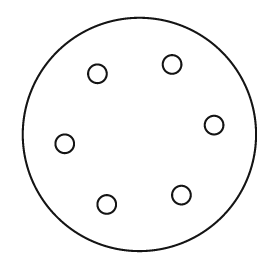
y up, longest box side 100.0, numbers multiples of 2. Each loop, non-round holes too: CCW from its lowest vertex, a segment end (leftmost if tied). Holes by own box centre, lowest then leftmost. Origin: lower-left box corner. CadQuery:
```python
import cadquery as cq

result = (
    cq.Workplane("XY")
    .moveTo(50.0, 50.0)
    .circle(50.0)
    .moveTo(36.0, 20.0)
    .circle(4.0)
    .moveTo(68.0, 24.0)
    .circle(4.0)
    .moveTo(18.0, 46.0)
    .circle(4.0)
    .moveTo(82.0, 54.0)
    .circle(4.0)
    .moveTo(32.0, 76.0)
    .circle(4.0)
    .moveTo(64.0, 80.0)
    .circle(4.0)
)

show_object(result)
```